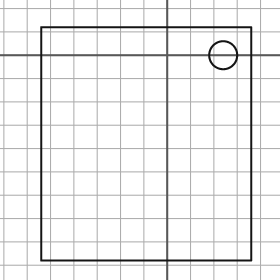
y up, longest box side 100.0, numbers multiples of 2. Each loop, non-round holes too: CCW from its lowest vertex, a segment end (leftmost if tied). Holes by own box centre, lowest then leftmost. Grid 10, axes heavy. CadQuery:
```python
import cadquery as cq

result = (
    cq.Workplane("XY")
    .moveTo(-54.0, -88.0)
    .lineTo(36.0, -88.0)
    .lineTo(36.0, 12.0)
    .lineTo(-54.0, 12.0)
    .close()
    .moveTo(24.0, 0.0)
    .circle(6.0)
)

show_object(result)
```